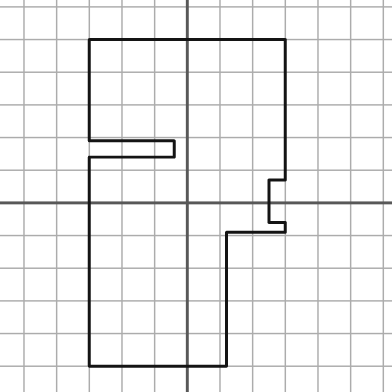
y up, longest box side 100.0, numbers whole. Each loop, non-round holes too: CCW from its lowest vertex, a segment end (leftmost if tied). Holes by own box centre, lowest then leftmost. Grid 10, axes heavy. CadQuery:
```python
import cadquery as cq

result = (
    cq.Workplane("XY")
    .moveTo(-30.0, -50.0)
    .lineTo(12.0, -50.0)
    .lineTo(12.0, -9.0)
    .lineTo(30.0, -9.0)
    .lineTo(30.0, -6.0)
    .lineTo(25.0, -6.0)
    .lineTo(25.0, 7.0)
    .lineTo(30.0, 7.0)
    .lineTo(30.0, 50.0)
    .lineTo(-30.0, 50.0)
    .lineTo(-30.0, 19.0)
    .lineTo(-4.0, 19.0)
    .lineTo(-4.0, 14.0)
    .lineTo(-30.0, 14.0)
    .close()
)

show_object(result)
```